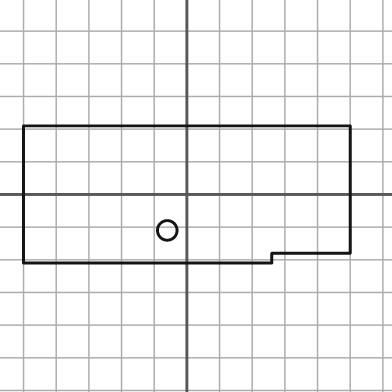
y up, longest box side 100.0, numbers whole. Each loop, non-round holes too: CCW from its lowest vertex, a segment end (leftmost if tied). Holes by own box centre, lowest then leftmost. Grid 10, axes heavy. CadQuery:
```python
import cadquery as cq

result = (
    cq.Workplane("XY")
    .moveTo(-50.0, -21.0)
    .lineTo(26.0, -21.0)
    .lineTo(26.0, -18.0)
    .lineTo(50.0, -18.0)
    .lineTo(50.0, 21.0)
    .lineTo(-50.0, 21.0)
    .close()
    .moveTo(-6.0, -11.0)
    .circle(3.0)
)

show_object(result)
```